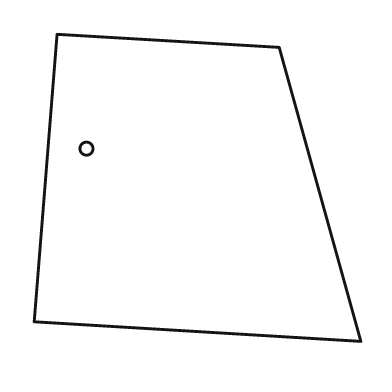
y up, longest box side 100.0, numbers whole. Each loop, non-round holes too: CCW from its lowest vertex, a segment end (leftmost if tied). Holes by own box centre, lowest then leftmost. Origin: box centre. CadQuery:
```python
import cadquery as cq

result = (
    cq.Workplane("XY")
    .moveTo(50.0, -47.0)
    .lineTo(25.0, 43.0)
    .lineTo(-43.0, 47.0)
    .lineTo(-50.0, -41.0)
    .close()
    .moveTo(-34.0, 12.0)
    .circle(2.0)
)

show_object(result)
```